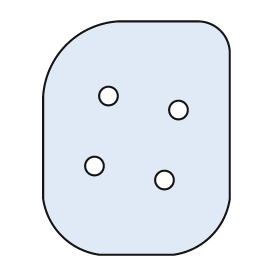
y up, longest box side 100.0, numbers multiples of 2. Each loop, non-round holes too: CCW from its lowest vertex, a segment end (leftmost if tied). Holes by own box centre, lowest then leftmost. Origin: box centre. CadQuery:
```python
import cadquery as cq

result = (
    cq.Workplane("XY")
    .moveTo(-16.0, -50.0)
    .lineTo(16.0, -50.0)
    .threePointArc((32.0, -42.0), (40.0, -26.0))
    .lineTo(40.0, 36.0)
    .threePointArc((36.0, 46.0), (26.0, 50.0))
    .lineTo(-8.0, 50.0)
    .threePointArc((-30.0, 40.0), (-40.0, 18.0))
    .lineTo(-40.0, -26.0)
    .threePointArc((-32.0, -42.0), (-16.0, -50.0))
    .close()
    .moveTo(12.0, -18.0)
    .circle(4.0)
    .moveTo(-18.0, -12.0)
    .circle(4.0)
    .moveTo(18.0, 12.0)
    .circle(4.0)
    .moveTo(-12.0, 18.0)
    .circle(4.0)
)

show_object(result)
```